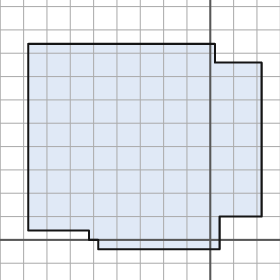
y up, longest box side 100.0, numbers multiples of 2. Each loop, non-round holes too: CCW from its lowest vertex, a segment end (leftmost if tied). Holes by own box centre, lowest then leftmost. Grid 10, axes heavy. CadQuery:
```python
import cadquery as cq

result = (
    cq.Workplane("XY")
    .moveTo(-48.0, -4.0)
    .lineTo(4.0, -4.0)
    .lineTo(4.0, 10.0)
    .lineTo(22.0, 10.0)
    .lineTo(22.0, 76.0)
    .lineTo(2.0, 76.0)
    .lineTo(2.0, 84.0)
    .lineTo(-78.0, 84.0)
    .lineTo(-78.0, 4.0)
    .lineTo(-52.0, 4.0)
    .lineTo(-52.0, 0.0)
    .lineTo(-48.0, 0.0)
    .close()
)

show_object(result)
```